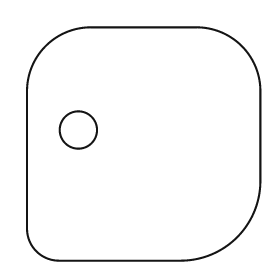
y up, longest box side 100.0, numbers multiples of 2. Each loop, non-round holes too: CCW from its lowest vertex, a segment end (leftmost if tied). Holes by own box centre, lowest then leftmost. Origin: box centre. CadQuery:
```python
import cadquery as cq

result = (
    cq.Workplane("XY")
    .moveTo(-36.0, -50.0)
    .lineTo(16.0, -50.0)
    .threePointArc((40.0, -40.0), (50.0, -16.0))
    .lineTo(50.0, 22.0)
    .threePointArc((42.0, 42.0), (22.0, 50.0))
    .lineTo(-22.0, 50.0)
    .threePointArc((-42.0, 42.0), (-50.0, 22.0))
    .lineTo(-50.0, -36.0)
    .threePointArc((-46.0, -46.0), (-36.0, -50.0))
    .close()
    .moveTo(-28.0, 6.0)
    .circle(8.0)
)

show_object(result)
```